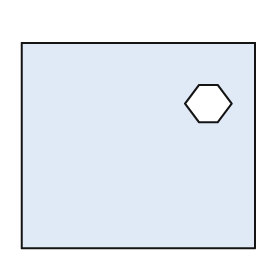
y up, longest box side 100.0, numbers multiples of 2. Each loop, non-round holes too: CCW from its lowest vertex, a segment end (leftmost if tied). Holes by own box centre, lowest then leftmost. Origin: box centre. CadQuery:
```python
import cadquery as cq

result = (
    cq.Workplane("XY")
    .moveTo(-50.0, -44.0)
    .lineTo(50.0, -44.0)
    .lineTo(50.0, 44.0)
    .lineTo(-50.0, 44.0)
    .close()
    .moveTo(26.0, 10.0)
    .lineTo(34.0, 10.0)
    .lineTo(40.0, 18.0)
    .lineTo(34.0, 26.0)
    .lineTo(26.0, 26.0)
    .lineTo(20.0, 18.0)
    .close()
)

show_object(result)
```